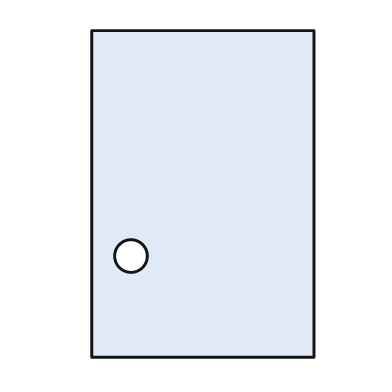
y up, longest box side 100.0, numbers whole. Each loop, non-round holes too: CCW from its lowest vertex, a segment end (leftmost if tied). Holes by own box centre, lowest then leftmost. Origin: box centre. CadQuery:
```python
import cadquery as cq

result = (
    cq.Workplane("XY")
    .moveTo(-34.0, -50.0)
    .lineTo(34.0, -50.0)
    .lineTo(34.0, 50.0)
    .lineTo(-34.0, 50.0)
    .close()
    .moveTo(-22.0, -19.0)
    .circle(5.0)
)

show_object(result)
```